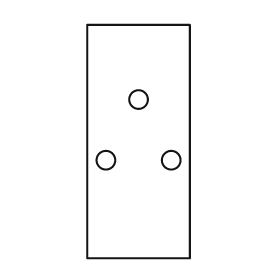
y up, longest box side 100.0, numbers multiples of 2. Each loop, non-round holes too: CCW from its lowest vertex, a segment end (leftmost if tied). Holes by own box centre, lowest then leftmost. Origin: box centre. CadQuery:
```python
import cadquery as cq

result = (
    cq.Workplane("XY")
    .moveTo(-22.0, -50.0)
    .lineTo(22.0, -50.0)
    .lineTo(22.0, 50.0)
    .lineTo(-22.0, 50.0)
    .close()
    .moveTo(-14.0, -8.0)
    .circle(4.0)
    .moveTo(14.0, -8.0)
    .circle(4.0)
    .moveTo(0.0, 18.0)
    .circle(4.0)
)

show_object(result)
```